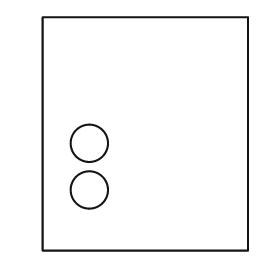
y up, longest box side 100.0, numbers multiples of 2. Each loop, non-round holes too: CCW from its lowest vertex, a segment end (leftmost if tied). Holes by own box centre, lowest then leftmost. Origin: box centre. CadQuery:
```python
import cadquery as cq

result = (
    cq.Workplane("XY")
    .moveTo(-44.0, -50.0)
    .lineTo(44.0, -50.0)
    .lineTo(44.0, 50.0)
    .lineTo(-44.0, 50.0)
    .close()
    .moveTo(-24.0, -24.0)
    .circle(8.0)
    .moveTo(-24.0, -4.0)
    .circle(8.0)
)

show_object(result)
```